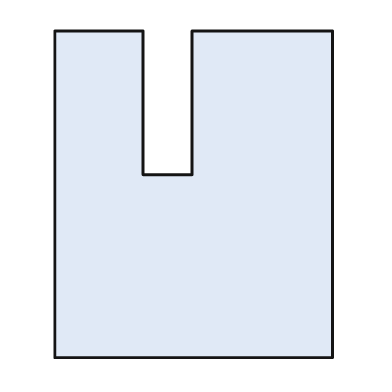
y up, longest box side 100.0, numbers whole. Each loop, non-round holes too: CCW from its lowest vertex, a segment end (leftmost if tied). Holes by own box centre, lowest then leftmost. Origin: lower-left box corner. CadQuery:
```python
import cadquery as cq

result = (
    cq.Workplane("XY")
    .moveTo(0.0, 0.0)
    .lineTo(85.0, 0.0)
    .lineTo(85.0, 100.0)
    .lineTo(42.0, 100.0)
    .lineTo(42.0, 56.0)
    .lineTo(27.0, 56.0)
    .lineTo(27.0, 100.0)
    .lineTo(0.0, 100.0)
    .close()
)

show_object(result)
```